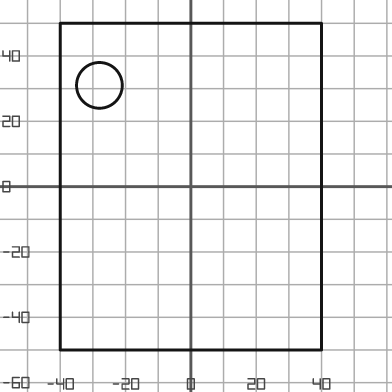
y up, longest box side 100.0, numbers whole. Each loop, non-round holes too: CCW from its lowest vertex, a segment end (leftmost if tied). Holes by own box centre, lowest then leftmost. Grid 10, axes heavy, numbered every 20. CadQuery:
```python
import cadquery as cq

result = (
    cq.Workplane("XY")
    .moveTo(-40.0, -50.0)
    .lineTo(40.0, -50.0)
    .lineTo(40.0, 50.0)
    .lineTo(-40.0, 50.0)
    .close()
    .moveTo(-28.0, 31.0)
    .circle(7.0)
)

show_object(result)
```